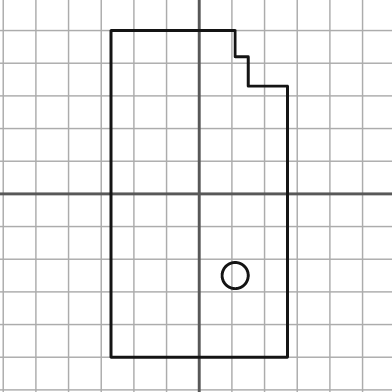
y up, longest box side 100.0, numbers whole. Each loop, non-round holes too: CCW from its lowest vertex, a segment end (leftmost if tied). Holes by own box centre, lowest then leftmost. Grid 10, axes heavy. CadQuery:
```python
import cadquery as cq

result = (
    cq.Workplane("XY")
    .moveTo(-27.0, -50.0)
    .lineTo(27.0, -50.0)
    .lineTo(27.0, 33.0)
    .lineTo(15.0, 33.0)
    .lineTo(15.0, 42.0)
    .lineTo(11.0, 42.0)
    .lineTo(11.0, 50.0)
    .lineTo(-27.0, 50.0)
    .close()
    .moveTo(11.0, -25.0)
    .circle(4.0)
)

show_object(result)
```